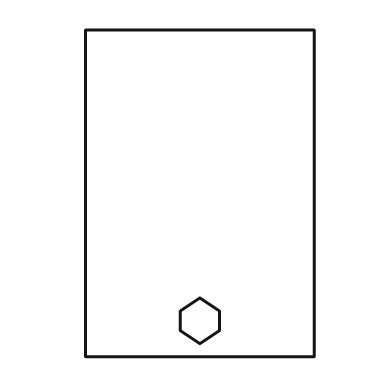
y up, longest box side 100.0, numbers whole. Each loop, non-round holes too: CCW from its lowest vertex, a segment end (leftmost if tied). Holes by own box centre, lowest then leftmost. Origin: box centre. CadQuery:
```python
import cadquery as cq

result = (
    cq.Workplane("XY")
    .moveTo(-35.0, -50.0)
    .lineTo(35.0, -50.0)
    .lineTo(35.0, 50.0)
    .lineTo(-35.0, 50.0)
    .close()
    .moveTo(0.0, -46.0)
    .lineTo(6.0, -42.0)
    .lineTo(6.0, -36.0)
    .lineTo(0.0, -32.0)
    .lineTo(-6.0, -36.0)
    .lineTo(-6.0, -42.0)
    .close()
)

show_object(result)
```